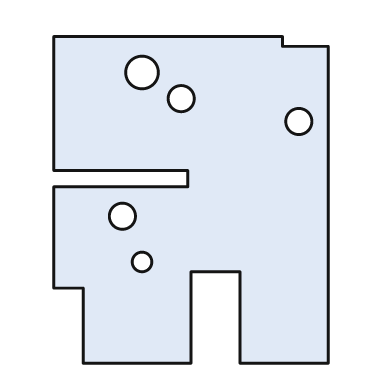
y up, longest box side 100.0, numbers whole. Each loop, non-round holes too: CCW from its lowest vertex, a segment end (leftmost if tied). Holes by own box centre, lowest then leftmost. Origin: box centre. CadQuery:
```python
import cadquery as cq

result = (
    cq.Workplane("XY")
    .moveTo(-33.0, -50.0)
    .lineTo(0.0, -50.0)
    .lineTo(0.0, -22.0)
    .lineTo(15.0, -22.0)
    .lineTo(15.0, -50.0)
    .lineTo(42.0, -50.0)
    .lineTo(42.0, 47.0)
    .lineTo(28.0, 47.0)
    .lineTo(28.0, 50.0)
    .lineTo(-42.0, 50.0)
    .lineTo(-42.0, 9.0)
    .lineTo(-1.0, 9.0)
    .lineTo(-1.0, 4.0)
    .lineTo(-42.0, 4.0)
    .lineTo(-42.0, -27.0)
    .lineTo(-33.0, -27.0)
    .close()
    .moveTo(-15.0, -19.0)
    .circle(3.0)
    .moveTo(-21.0, -5.0)
    .circle(4.0)
    .moveTo(33.0, 24.0)
    .circle(4.0)
    .moveTo(-3.0, 31.0)
    .circle(4.0)
    .moveTo(-15.0, 39.0)
    .circle(5.0)
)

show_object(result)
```